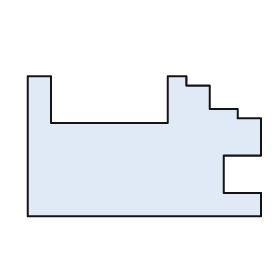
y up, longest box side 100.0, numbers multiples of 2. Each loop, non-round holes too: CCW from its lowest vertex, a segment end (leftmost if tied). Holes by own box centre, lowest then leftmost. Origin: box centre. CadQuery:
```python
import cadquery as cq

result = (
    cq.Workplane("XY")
    .moveTo(-50.0, -30.0)
    .lineTo(50.0, -30.0)
    .lineTo(50.0, -20.0)
    .lineTo(34.0, -20.0)
    .lineTo(34.0, -4.0)
    .lineTo(50.0, -4.0)
    .lineTo(50.0, 12.0)
    .lineTo(40.0, 12.0)
    .lineTo(40.0, 16.0)
    .lineTo(28.0, 16.0)
    .lineTo(28.0, 26.0)
    .lineTo(18.0, 26.0)
    .lineTo(18.0, 30.0)
    .lineTo(10.0, 30.0)
    .lineTo(10.0, 10.0)
    .lineTo(-40.0, 10.0)
    .lineTo(-40.0, 30.0)
    .lineTo(-50.0, 30.0)
    .close()
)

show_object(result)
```